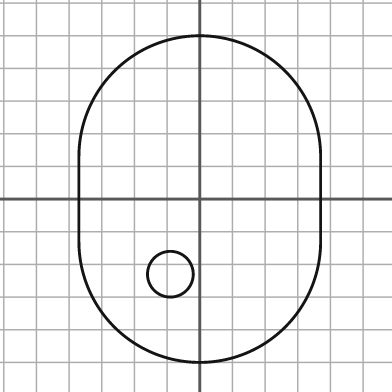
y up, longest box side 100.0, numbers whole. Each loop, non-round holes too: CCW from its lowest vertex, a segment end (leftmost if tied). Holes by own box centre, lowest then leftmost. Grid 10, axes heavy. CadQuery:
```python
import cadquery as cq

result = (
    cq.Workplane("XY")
    .moveTo(-37.0, -13.0)
    .threePointArc((0.0, -50.0), (37.0, -13.0))
    .lineTo(37.0, 13.0)
    .threePointArc((0.0, 50.0), (-37.0, 13.0))
    .close()
    .moveTo(-9.0, -23.0)
    .circle(7.0)
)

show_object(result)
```